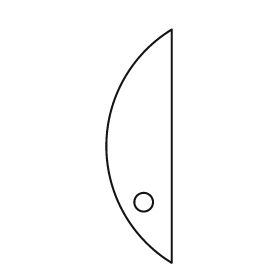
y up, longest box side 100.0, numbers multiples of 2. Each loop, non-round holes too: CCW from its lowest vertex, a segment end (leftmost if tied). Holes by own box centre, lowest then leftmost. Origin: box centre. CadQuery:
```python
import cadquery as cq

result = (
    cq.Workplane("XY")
    .moveTo(14.0, -50.0)
    .lineTo(14.0, 50.0)
    .threePointArc((-14.0, 0.0), (14.0, -50.0))
    .close()
    .moveTo(2.0, -24.0)
    .circle(4.0)
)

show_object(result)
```